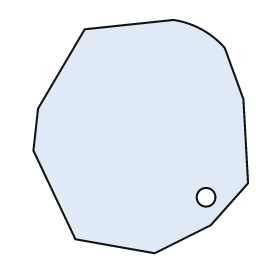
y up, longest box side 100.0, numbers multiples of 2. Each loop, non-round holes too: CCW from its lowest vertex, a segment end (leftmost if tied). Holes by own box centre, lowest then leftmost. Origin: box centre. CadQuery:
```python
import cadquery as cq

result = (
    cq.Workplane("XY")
    .moveTo(6.0, -50.0)
    .lineTo(30.0, -38.0)
    .lineTo(46.0, -20.0)
    .lineTo(44.0, 16.0)
    .lineTo(36.0, 38.0)
    .threePointArc((26.0, 46.0), (14.0, 50.0))
    .lineTo(-24.0, 46.0)
    .lineTo(-44.0, 12.0)
    .lineTo(-46.0, -6.0)
    .lineTo(-28.0, -44.0)
    .close()
    .moveTo(28.0, -26.0)
    .circle(4.0)
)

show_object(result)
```